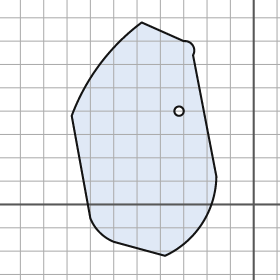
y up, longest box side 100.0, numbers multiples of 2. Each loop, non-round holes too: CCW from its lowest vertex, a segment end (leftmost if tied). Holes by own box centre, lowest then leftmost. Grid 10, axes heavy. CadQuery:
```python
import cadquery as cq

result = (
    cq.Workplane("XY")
    .moveTo(-38.0, -22.0)
    .threePointArc((-22.0, -8.0), (-16.0, 12.0))
    .lineTo(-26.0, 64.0)
    .threePointArc((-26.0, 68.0), (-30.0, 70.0))
    .lineTo(-48.0, 78.0)
    .threePointArc((-66.0, 60.0), (-78.0, 38.0))
    .lineTo(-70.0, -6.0)
    .threePointArc((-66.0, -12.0), (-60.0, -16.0))
    .close()
    .moveTo(-32.0, 40.0)
    .circle(2.0)
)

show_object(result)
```